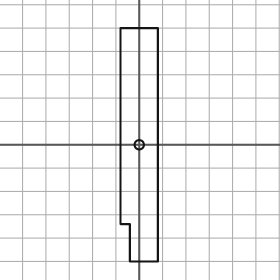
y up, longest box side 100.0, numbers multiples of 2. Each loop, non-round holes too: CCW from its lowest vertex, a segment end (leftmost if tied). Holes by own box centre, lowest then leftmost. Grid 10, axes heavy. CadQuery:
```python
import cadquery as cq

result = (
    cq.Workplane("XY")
    .moveTo(-4.0, -50.0)
    .lineTo(8.0, -50.0)
    .lineTo(8.0, 50.0)
    .lineTo(-8.0, 50.0)
    .lineTo(-8.0, -34.0)
    .lineTo(-4.0, -34.0)
    .close()
    .moveTo(0.0, 0.0)
    .circle(2.0)
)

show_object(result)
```